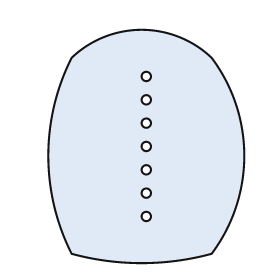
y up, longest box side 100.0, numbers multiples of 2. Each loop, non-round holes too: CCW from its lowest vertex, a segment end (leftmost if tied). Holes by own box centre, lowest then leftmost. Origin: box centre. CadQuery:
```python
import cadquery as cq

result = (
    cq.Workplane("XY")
    .moveTo(-32.0, -46.0)
    .threePointArc((-2.0, -50.0), (28.0, -46.0))
    .threePointArc((42.0, -4.0), (28.0, 38.0))
    .threePointArc((-2.0, 50.0), (-32.0, 38.0))
    .threePointArc((-42.0, -4.0), (-32.0, -46.0))
    .close()
    .moveTo(0.0, -30.0)
    .circle(2.0)
    .moveTo(0.0, -20.0)
    .circle(2.0)
    .moveTo(0.0, -10.0)
    .circle(2.0)
    .moveTo(0.0, 0.0)
    .circle(2.0)
    .moveTo(0.0, 10.0)
    .circle(2.0)
    .moveTo(0.0, 20.0)
    .circle(2.0)
    .moveTo(0.0, 30.0)
    .circle(2.0)
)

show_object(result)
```